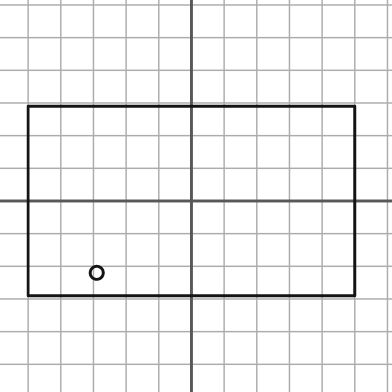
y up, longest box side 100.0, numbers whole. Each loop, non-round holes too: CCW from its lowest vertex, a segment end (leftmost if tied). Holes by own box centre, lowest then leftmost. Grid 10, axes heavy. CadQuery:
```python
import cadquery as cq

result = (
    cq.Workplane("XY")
    .moveTo(-50.0, -29.0)
    .lineTo(50.0, -29.0)
    .lineTo(50.0, 29.0)
    .lineTo(-50.0, 29.0)
    .close()
    .moveTo(-29.0, -22.0)
    .circle(2.0)
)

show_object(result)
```